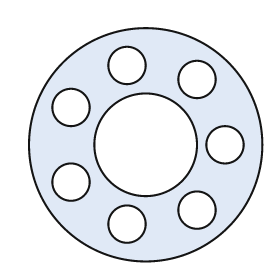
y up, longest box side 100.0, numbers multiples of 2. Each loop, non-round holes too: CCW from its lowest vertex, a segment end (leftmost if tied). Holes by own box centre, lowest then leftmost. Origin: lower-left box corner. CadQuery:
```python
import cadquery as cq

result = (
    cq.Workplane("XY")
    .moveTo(50.0, 50.0)
    .circle(50.0)
    .moveTo(42.0, 16.0)
    .circle(8.0)
    .moveTo(72.0, 22.0)
    .circle(8.0)
    .moveTo(18.0, 34.0)
    .circle(8.0)
    .moveTo(50.0, 50.0)
    .circle(22.0)
    .moveTo(84.0, 50.0)
    .circle(8.0)
    .moveTo(18.0, 66.0)
    .circle(8.0)
    .moveTo(72.0, 78.0)
    .circle(8.0)
    .moveTo(42.0, 84.0)
    .circle(8.0)
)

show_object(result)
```